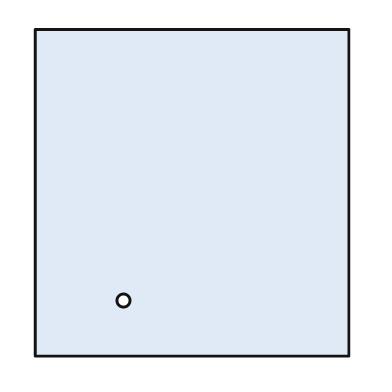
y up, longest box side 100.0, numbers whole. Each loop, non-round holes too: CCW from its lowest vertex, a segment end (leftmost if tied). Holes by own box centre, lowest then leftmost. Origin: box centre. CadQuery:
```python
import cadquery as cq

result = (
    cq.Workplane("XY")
    .moveTo(-48.0, -50.0)
    .lineTo(48.0, -50.0)
    .lineTo(48.0, 50.0)
    .lineTo(-48.0, 50.0)
    .close()
    .moveTo(-21.0, -33.0)
    .circle(2.0)
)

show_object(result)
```